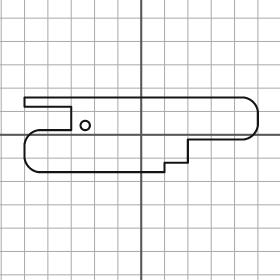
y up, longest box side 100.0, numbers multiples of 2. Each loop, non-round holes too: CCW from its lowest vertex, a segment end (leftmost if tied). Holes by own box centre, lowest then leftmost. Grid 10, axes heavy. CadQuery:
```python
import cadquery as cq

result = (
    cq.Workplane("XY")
    .moveTo(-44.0, -16.0)
    .lineTo(10.0, -16.0)
    .lineTo(10.0, -12.0)
    .lineTo(20.0, -12.0)
    .lineTo(20.0, -2.0)
    .lineTo(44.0, -2.0)
    .threePointArc((48.0, 0.0), (50.0, 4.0))
    .lineTo(50.0, 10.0)
    .threePointArc((48.0, 14.0), (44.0, 16.0))
    .lineTo(-50.0, 16.0)
    .lineTo(-50.0, 12.0)
    .lineTo(-30.0, 12.0)
    .lineTo(-30.0, 2.0)
    .lineTo(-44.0, 2.0)
    .threePointArc((-48.0, 0.0), (-50.0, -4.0))
    .lineTo(-50.0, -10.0)
    .threePointArc((-48.0, -14.0), (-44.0, -16.0))
    .close()
    .moveTo(-24.0, 4.0)
    .circle(2.0)
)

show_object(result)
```